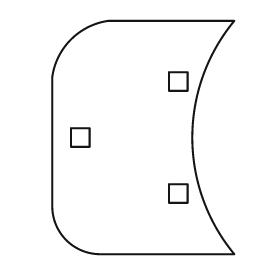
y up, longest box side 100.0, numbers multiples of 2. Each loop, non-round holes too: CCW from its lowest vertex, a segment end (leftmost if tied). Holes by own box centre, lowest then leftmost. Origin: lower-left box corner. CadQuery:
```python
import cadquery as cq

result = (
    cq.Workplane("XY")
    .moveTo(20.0, 0.0)
    .lineTo(78.0, 0.0)
    .threePointArc((60.0, 50.0), (78.0, 100.0))
    .lineTo(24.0, 100.0)
    .threePointArc((8.0, 92.0), (0.0, 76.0))
    .lineTo(0.0, 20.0)
    .threePointArc((6.0, 6.0), (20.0, 0.0))
    .close()
    .moveTo(50.0, 22.0)
    .lineTo(58.0, 22.0)
    .lineTo(58.0, 30.0)
    .lineTo(50.0, 30.0)
    .close()
    .moveTo(8.0, 46.0)
    .lineTo(16.0, 46.0)
    .lineTo(16.0, 54.0)
    .lineTo(8.0, 54.0)
    .close()
    .moveTo(50.0, 70.0)
    .lineTo(58.0, 70.0)
    .lineTo(58.0, 78.0)
    .lineTo(50.0, 78.0)
    .close()
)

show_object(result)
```